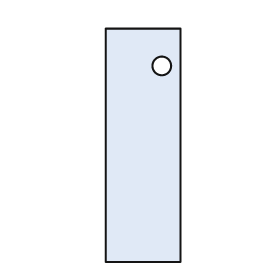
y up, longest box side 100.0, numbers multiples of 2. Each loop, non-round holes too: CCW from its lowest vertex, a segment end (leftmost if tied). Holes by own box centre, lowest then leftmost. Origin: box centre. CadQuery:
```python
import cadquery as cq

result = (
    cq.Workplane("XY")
    .moveTo(-16.0, -50.0)
    .lineTo(16.0, -50.0)
    .lineTo(16.0, 50.0)
    .lineTo(-16.0, 50.0)
    .close()
    .moveTo(8.0, 34.0)
    .circle(4.0)
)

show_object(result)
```